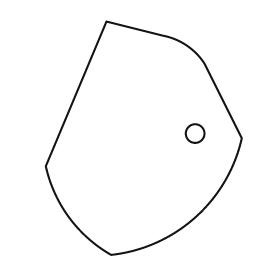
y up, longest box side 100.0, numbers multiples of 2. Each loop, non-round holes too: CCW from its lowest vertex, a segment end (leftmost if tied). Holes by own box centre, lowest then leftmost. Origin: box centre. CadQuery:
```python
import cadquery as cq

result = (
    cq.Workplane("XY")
    .moveTo(-14.0, -50.0)
    .threePointArc((22.0, -34.0), (42.0, 0.0))
    .lineTo(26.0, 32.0)
    .threePointArc((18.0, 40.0), (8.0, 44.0))
    .lineTo(-16.0, 50.0)
    .lineTo(-42.0, -12.0)
    .threePointArc((-32.0, -34.0), (-14.0, -50.0))
    .close()
    .moveTo(22.0, 2.0)
    .circle(4.0)
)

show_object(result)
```